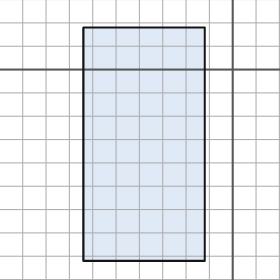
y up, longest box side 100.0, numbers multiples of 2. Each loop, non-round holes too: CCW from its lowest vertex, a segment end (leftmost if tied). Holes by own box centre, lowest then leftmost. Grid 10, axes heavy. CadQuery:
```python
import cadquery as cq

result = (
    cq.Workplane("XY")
    .moveTo(-64.0, -82.0)
    .lineTo(-12.0, -82.0)
    .lineTo(-12.0, 18.0)
    .lineTo(-64.0, 18.0)
    .close()
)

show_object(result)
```